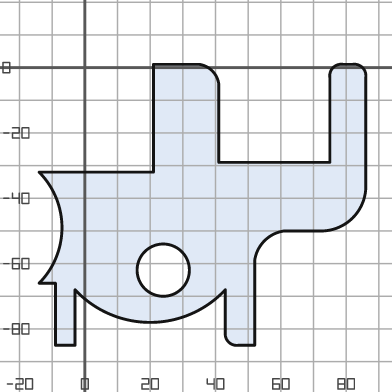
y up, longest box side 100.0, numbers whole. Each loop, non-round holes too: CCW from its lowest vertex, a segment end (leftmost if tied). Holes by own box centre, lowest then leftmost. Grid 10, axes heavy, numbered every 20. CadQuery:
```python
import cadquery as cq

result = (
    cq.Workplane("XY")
    .moveTo(-9.0, -85.0)
    .lineTo(-3.0, -85.0)
    .lineTo(-3.0, -68.0)
    .threePointArc((20.0, -78.0), (43.0, -68.0))
    .lineTo(43.0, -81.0)
    .threePointArc((44.0, -84.0), (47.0, -85.0))
    .lineTo(52.0, -85.0)
    .lineTo(52.0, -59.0)
    .threePointArc((55.0, -53.0), (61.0, -50.0))
    .lineTo(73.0, -50.0)
    .threePointArc((82.0, -46.0), (86.0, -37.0))
    .lineTo(86.0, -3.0)
    .threePointArc((85.0, 0.0), (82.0, 1.0))
    .lineTo(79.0, 1.0)
    .threePointArc((76.0, 0.0), (75.0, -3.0))
    .lineTo(75.0, -29.0)
    .lineTo(41.0, -29.0)
    .lineTo(41.0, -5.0)
    .threePointArc((39.0, -1.0), (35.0, 1.0))
    .lineTo(21.0, 1.0)
    .lineTo(21.0, -32.0)
    .lineTo(-14.0, -32.0)
    .threePointArc((-7.0, -49.0), (-14.0, -66.0))
    .lineTo(-9.0, -66.0)
    .close()
    .moveTo(24.0, -62.0)
    .circle(8.0)
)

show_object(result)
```